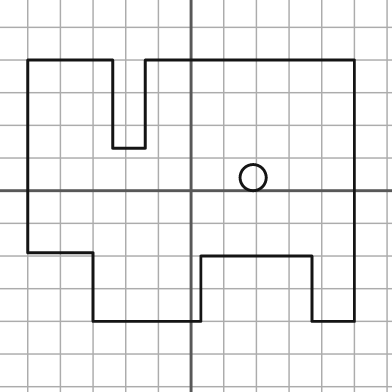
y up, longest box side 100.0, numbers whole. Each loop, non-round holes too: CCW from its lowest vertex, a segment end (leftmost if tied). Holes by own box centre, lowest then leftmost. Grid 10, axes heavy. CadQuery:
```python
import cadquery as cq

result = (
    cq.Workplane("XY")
    .moveTo(-30.0, -40.0)
    .lineTo(3.0, -40.0)
    .lineTo(3.0, -20.0)
    .lineTo(37.0, -20.0)
    .lineTo(37.0, -40.0)
    .lineTo(50.0, -40.0)
    .lineTo(50.0, 40.0)
    .lineTo(-14.0, 40.0)
    .lineTo(-14.0, 13.0)
    .lineTo(-24.0, 13.0)
    .lineTo(-24.0, 40.0)
    .lineTo(-50.0, 40.0)
    .lineTo(-50.0, -19.0)
    .lineTo(-30.0, -19.0)
    .close()
    .moveTo(19.0, 4.0)
    .circle(4.0)
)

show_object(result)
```